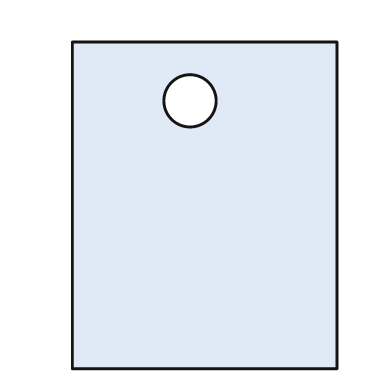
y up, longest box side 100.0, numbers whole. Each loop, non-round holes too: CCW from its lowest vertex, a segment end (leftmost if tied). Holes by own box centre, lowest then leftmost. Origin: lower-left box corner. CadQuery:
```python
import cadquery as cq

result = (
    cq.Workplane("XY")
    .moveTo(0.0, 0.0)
    .lineTo(81.0, 0.0)
    .lineTo(81.0, 100.0)
    .lineTo(0.0, 100.0)
    .close()
    .moveTo(36.0, 82.0)
    .circle(8.0)
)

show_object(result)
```